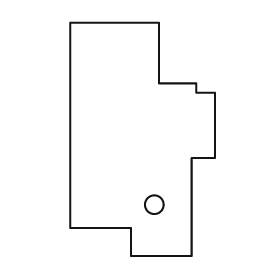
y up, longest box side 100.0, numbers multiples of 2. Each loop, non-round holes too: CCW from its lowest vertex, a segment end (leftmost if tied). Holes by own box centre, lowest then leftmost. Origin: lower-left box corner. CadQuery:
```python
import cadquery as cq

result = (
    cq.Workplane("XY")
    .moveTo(26.0, 0.0)
    .lineTo(52.0, 0.0)
    .lineTo(52.0, 42.0)
    .lineTo(62.0, 42.0)
    .lineTo(62.0, 70.0)
    .lineTo(54.0, 70.0)
    .lineTo(54.0, 74.0)
    .lineTo(38.0, 74.0)
    .lineTo(38.0, 100.0)
    .lineTo(0.0, 100.0)
    .lineTo(0.0, 12.0)
    .lineTo(26.0, 12.0)
    .close()
    .moveTo(36.0, 22.0)
    .circle(4.0)
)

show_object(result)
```